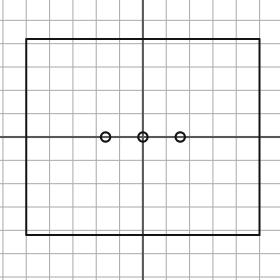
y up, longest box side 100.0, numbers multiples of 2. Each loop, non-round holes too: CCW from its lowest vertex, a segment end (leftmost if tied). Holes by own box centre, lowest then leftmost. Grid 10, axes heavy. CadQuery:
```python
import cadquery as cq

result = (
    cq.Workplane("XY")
    .moveTo(-50.0, -42.0)
    .lineTo(50.0, -42.0)
    .lineTo(50.0, 42.0)
    .lineTo(-50.0, 42.0)
    .close()
    .moveTo(-16.0, 0.0)
    .circle(2.0)
    .moveTo(0.0, 0.0)
    .circle(2.0)
    .moveTo(16.0, 0.0)
    .circle(2.0)
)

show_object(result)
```